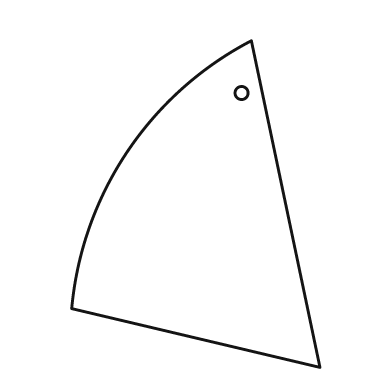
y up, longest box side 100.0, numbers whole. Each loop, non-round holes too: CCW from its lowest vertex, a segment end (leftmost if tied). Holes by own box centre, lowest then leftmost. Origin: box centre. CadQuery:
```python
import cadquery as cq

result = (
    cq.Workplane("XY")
    .moveTo(38.0, -50.0)
    .lineTo(17.0, 50.0)
    .threePointArc((-21.0, 16.0), (-38.0, -32.0))
    .close()
    .moveTo(14.0, 34.0)
    .circle(2.0)
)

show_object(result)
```